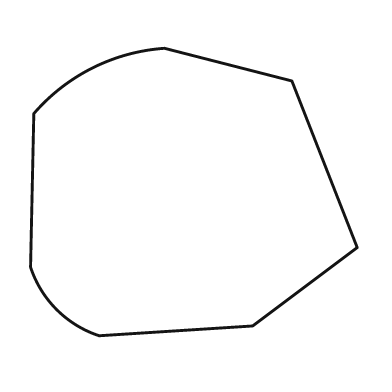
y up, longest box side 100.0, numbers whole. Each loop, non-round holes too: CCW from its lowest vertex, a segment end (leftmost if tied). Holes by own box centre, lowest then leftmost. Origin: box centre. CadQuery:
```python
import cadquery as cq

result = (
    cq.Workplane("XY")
    .moveTo(-29.0, -44.0)
    .lineTo(18.0, -41.0)
    .lineTo(50.0, -17.0)
    .lineTo(30.0, 34.0)
    .lineTo(-9.0, 44.0)
    .threePointArc((-31.0, 38.0), (-49.0, 24.0))
    .lineTo(-50.0, -23.0)
    .threePointArc((-42.0, -36.0), (-29.0, -44.0))
    .close()
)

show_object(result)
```